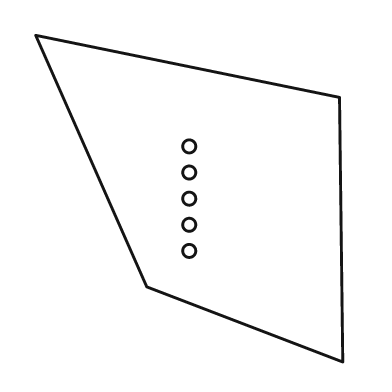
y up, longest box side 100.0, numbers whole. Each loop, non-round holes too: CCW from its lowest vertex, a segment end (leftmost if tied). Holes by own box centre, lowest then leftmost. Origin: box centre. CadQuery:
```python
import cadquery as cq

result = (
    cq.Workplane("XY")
    .moveTo(47.0, -50.0)
    .lineTo(46.0, 31.0)
    .lineTo(-47.0, 50.0)
    .lineTo(-13.0, -27.0)
    .close()
    .moveTo(0.0, -16.0)
    .circle(2.0)
    .moveTo(0.0, -8.0)
    .circle(2.0)
    .moveTo(0.0, 0.0)
    .circle(2.0)
    .moveTo(0.0, 8.0)
    .circle(2.0)
    .moveTo(0.0, 16.0)
    .circle(2.0)
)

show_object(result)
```